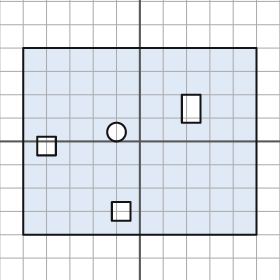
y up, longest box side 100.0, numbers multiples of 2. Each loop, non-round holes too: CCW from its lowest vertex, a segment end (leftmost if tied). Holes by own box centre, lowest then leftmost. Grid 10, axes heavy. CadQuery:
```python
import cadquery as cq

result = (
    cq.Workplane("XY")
    .moveTo(-50.0, -40.0)
    .lineTo(50.0, -40.0)
    .lineTo(50.0, 40.0)
    .lineTo(-50.0, 40.0)
    .close()
    .moveTo(-12.0, -34.0)
    .lineTo(-4.0, -34.0)
    .lineTo(-4.0, -26.0)
    .lineTo(-12.0, -26.0)
    .close()
    .moveTo(-44.0, -6.0)
    .lineTo(-36.0, -6.0)
    .lineTo(-36.0, 2.0)
    .lineTo(-44.0, 2.0)
    .close()
    .moveTo(-10.0, 4.0)
    .circle(4.0)
    .moveTo(18.0, 8.0)
    .lineTo(26.0, 8.0)
    .lineTo(26.0, 20.0)
    .lineTo(18.0, 20.0)
    .close()
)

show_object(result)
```